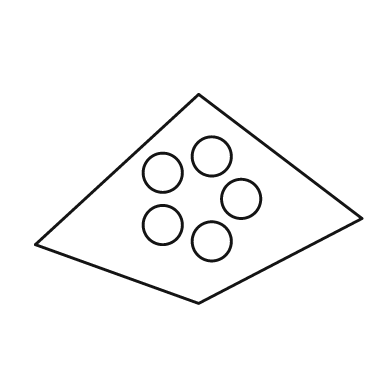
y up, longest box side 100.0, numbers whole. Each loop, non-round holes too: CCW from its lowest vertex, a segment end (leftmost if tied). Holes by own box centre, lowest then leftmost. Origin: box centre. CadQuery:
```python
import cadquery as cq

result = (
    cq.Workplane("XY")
    .moveTo(0.0, -32.0)
    .lineTo(50.0, -6.0)
    .lineTo(0.0, 32.0)
    .lineTo(-50.0, -14.0)
    .close()
    .moveTo(4.0, -13.0)
    .circle(6.0)
    .moveTo(-11.0, -8.0)
    .circle(6.0)
    .moveTo(13.0, 0.0)
    .circle(6.0)
    .moveTo(-11.0, 8.0)
    .circle(6.0)
    .moveTo(4.0, 13.0)
    .circle(6.0)
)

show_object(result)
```